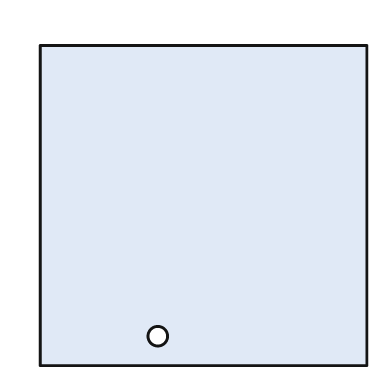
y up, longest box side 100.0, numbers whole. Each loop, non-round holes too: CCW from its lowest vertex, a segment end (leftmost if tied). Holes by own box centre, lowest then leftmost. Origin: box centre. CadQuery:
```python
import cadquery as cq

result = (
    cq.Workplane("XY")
    .moveTo(-50.0, -49.0)
    .lineTo(50.0, -49.0)
    .lineTo(50.0, 49.0)
    .lineTo(-50.0, 49.0)
    .close()
    .moveTo(-14.0, -40.0)
    .circle(3.0)
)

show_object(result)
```